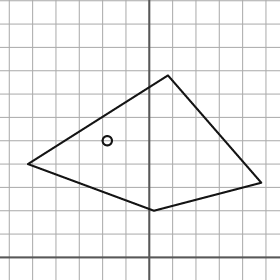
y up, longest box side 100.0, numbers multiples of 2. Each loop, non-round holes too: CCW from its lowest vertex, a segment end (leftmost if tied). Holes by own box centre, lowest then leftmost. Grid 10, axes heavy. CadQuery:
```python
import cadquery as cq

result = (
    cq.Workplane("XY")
    .moveTo(2.0, 20.0)
    .lineTo(48.0, 32.0)
    .lineTo(8.0, 78.0)
    .lineTo(-52.0, 40.0)
    .close()
    .moveTo(-18.0, 50.0)
    .circle(2.0)
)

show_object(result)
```